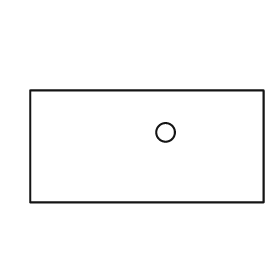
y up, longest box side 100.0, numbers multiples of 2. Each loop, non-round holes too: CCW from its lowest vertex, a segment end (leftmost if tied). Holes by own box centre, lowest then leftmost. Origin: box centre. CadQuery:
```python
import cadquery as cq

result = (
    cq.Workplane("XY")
    .moveTo(-50.0, -24.0)
    .lineTo(50.0, -24.0)
    .lineTo(50.0, 24.0)
    .lineTo(-50.0, 24.0)
    .close()
    .moveTo(8.0, 6.0)
    .circle(4.0)
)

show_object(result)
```